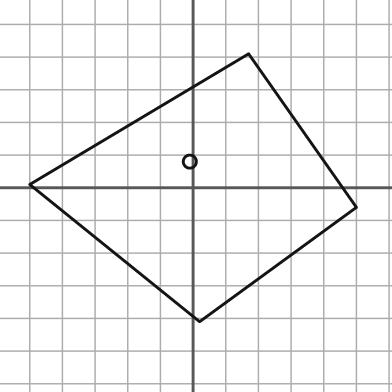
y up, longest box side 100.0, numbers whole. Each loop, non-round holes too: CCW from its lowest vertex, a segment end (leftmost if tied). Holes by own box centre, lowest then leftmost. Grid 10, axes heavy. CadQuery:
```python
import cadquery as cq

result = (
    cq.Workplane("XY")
    .moveTo(2.0, -41.0)
    .lineTo(50.0, -6.0)
    .lineTo(17.0, 41.0)
    .lineTo(-50.0, 1.0)
    .close()
    .moveTo(-1.0, 8.0)
    .circle(2.0)
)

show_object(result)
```